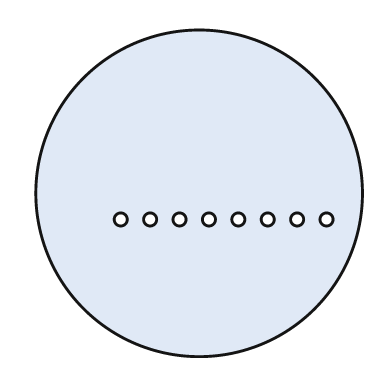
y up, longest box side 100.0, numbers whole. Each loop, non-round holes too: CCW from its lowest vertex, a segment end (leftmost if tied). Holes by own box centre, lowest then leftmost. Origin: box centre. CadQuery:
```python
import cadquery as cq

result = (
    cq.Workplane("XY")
    .moveTo(0.0, 0.0)
    .circle(50.0)
    .moveTo(-24.0, -8.0)
    .circle(2.0)
    .moveTo(-15.0, -8.0)
    .circle(2.0)
    .moveTo(-6.0, -8.0)
    .circle(2.0)
    .moveTo(3.0, -8.0)
    .circle(2.0)
    .moveTo(12.0, -8.0)
    .circle(2.0)
    .moveTo(21.0, -8.0)
    .circle(2.0)
    .moveTo(30.0, -8.0)
    .circle(2.0)
    .moveTo(39.0, -8.0)
    .circle(2.0)
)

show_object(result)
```